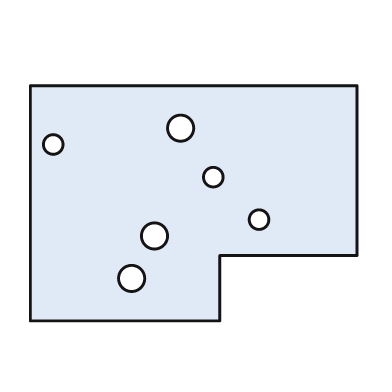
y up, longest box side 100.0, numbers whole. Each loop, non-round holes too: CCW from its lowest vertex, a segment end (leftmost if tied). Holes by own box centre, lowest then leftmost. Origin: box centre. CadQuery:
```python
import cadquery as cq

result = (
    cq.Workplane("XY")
    .moveTo(-50.0, -36.0)
    .lineTo(8.0, -36.0)
    .lineTo(8.0, -16.0)
    .lineTo(50.0, -16.0)
    .lineTo(50.0, 36.0)
    .lineTo(-50.0, 36.0)
    .close()
    .moveTo(-19.0, -23.0)
    .circle(4.0)
    .moveTo(-12.0, -10.0)
    .circle(4.0)
    .moveTo(20.0, -5.0)
    .circle(3.0)
    .moveTo(6.0, 8.0)
    .circle(3.0)
    .moveTo(-43.0, 18.0)
    .circle(3.0)
    .moveTo(-4.0, 23.0)
    .circle(4.0)
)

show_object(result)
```